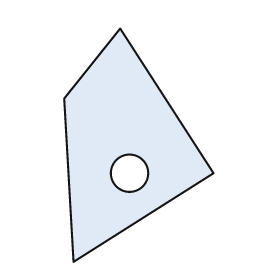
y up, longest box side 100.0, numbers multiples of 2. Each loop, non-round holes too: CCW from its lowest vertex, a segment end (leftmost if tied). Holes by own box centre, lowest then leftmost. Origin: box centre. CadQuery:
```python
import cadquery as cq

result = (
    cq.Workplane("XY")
    .moveTo(-28.0, -50.0)
    .lineTo(32.0, -12.0)
    .lineTo(-8.0, 50.0)
    .lineTo(-32.0, 20.0)
    .close()
    .moveTo(-4.0, -12.0)
    .circle(8.0)
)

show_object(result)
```